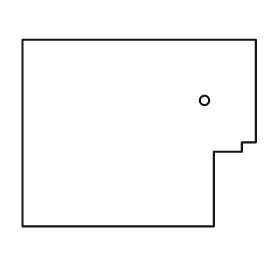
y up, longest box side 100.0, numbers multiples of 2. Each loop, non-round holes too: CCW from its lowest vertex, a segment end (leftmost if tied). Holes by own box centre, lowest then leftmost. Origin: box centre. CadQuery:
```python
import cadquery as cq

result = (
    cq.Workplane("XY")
    .moveTo(-50.0, -40.0)
    .lineTo(32.0, -40.0)
    .lineTo(32.0, -8.0)
    .lineTo(44.0, -8.0)
    .lineTo(44.0, -4.0)
    .lineTo(50.0, -4.0)
    .lineTo(50.0, 40.0)
    .lineTo(-50.0, 40.0)
    .close()
    .moveTo(28.0, 14.0)
    .circle(2.0)
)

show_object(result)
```